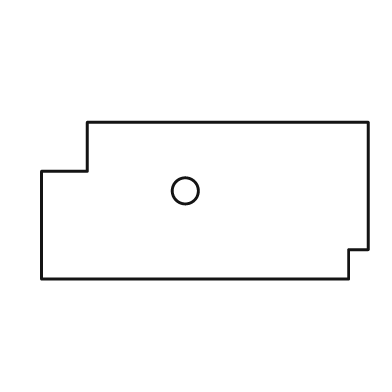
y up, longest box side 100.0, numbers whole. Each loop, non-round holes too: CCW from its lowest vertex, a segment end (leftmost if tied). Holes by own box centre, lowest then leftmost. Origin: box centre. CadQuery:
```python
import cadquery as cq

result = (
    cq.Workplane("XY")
    .moveTo(-50.0, -24.0)
    .lineTo(44.0, -24.0)
    .lineTo(44.0, -15.0)
    .lineTo(50.0, -15.0)
    .lineTo(50.0, 24.0)
    .lineTo(-36.0, 24.0)
    .lineTo(-36.0, 9.0)
    .lineTo(-50.0, 9.0)
    .close()
    .moveTo(-6.0, 3.0)
    .circle(4.0)
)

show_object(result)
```